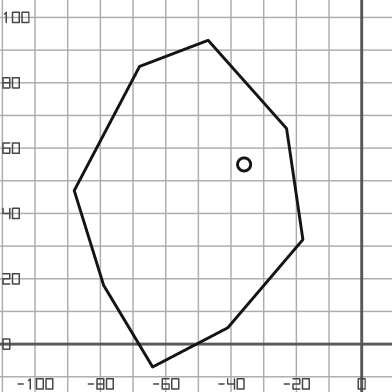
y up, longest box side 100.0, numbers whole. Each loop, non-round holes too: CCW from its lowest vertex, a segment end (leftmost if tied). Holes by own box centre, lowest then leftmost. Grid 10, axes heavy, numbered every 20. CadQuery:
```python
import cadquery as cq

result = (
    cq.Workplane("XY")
    .moveTo(-64.0, -7.0)
    .lineTo(-41.0, 5.0)
    .lineTo(-18.0, 32.0)
    .lineTo(-23.0, 66.0)
    .lineTo(-47.0, 93.0)
    .lineTo(-68.0, 85.0)
    .lineTo(-88.0, 47.0)
    .lineTo(-79.0, 18.0)
    .close()
    .moveTo(-36.0, 55.0)
    .circle(2.0)
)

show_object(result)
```